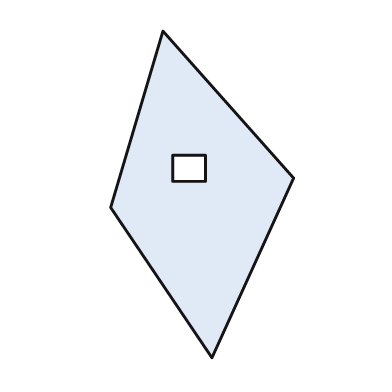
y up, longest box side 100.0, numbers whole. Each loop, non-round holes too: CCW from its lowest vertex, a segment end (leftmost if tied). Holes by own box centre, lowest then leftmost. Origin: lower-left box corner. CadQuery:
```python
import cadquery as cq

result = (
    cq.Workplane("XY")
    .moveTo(31.0, 0.0)
    .lineTo(56.0, 55.0)
    .lineTo(16.0, 100.0)
    .lineTo(0.0, 46.0)
    .close()
    .moveTo(19.0, 54.0)
    .lineTo(29.0, 54.0)
    .lineTo(29.0, 62.0)
    .lineTo(19.0, 62.0)
    .close()
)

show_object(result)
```